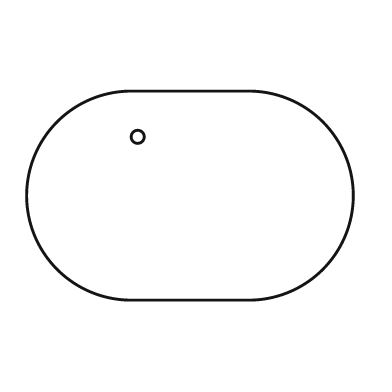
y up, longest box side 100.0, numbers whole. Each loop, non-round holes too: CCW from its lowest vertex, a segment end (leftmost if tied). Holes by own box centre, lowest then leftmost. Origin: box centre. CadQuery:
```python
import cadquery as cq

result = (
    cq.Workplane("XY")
    .moveTo(-18.0, -32.0)
    .lineTo(18.0, -32.0)
    .threePointArc((50.0, 0.0), (18.0, 32.0))
    .lineTo(-18.0, 32.0)
    .threePointArc((-50.0, 0.0), (-18.0, -32.0))
    .close()
    .moveTo(-16.0, 18.0)
    .circle(2.0)
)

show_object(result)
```